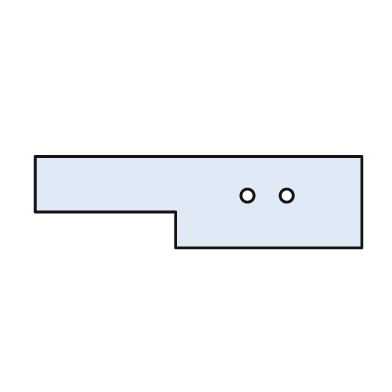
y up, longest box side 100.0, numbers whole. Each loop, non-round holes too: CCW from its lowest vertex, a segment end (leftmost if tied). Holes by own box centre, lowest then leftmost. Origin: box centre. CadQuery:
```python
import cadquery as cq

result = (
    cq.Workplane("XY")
    .moveTo(-7.0, -14.0)
    .lineTo(50.0, -14.0)
    .lineTo(50.0, 14.0)
    .lineTo(-50.0, 14.0)
    .lineTo(-50.0, -3.0)
    .lineTo(-7.0, -3.0)
    .close()
    .moveTo(15.0, 2.0)
    .circle(2.0)
    .moveTo(27.0, 2.0)
    .circle(2.0)
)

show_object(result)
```